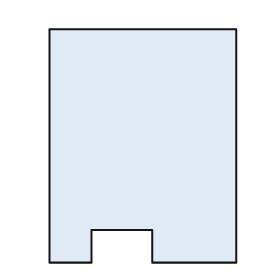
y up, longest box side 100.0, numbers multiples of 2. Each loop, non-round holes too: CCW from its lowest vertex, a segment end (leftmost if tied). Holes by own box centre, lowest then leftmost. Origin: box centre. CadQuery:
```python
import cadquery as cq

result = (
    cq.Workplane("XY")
    .moveTo(-40.0, -50.0)
    .lineTo(-22.0, -50.0)
    .lineTo(-22.0, -36.0)
    .lineTo(4.0, -36.0)
    .lineTo(4.0, -50.0)
    .lineTo(40.0, -50.0)
    .lineTo(40.0, 50.0)
    .lineTo(-40.0, 50.0)
    .close()
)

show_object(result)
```